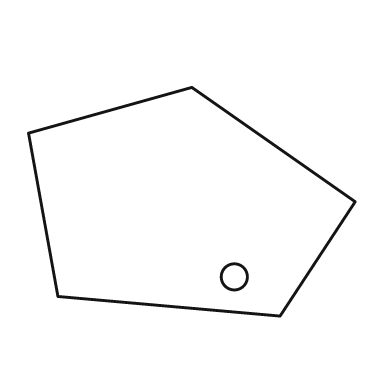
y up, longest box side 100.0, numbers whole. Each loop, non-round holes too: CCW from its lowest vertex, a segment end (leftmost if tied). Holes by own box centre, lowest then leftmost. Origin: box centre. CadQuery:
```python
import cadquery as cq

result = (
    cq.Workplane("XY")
    .moveTo(27.0, -35.0)
    .lineTo(50.0, 0.0)
    .lineTo(0.0, 35.0)
    .lineTo(-50.0, 21.0)
    .lineTo(-41.0, -29.0)
    .close()
    .moveTo(13.0, -23.0)
    .circle(4.0)
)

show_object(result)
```